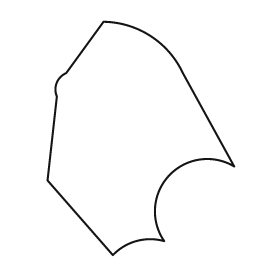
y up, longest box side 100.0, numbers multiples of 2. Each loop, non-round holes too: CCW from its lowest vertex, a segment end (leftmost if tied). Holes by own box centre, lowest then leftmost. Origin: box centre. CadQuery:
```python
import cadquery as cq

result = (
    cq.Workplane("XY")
    .moveTo(-12.0, -50.0)
    .threePointArc((-2.0, -44.0), (10.0, -44.0))
    .threePointArc((12.0, -16.0), (40.0, -12.0))
    .lineTo(18.0, 28.0)
    .threePointArc((4.0, 44.0), (-16.0, 50.0))
    .lineTo(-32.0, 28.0)
    .threePointArc((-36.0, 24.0), (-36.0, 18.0))
    .lineTo(-40.0, -18.0)
    .close()
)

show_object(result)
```